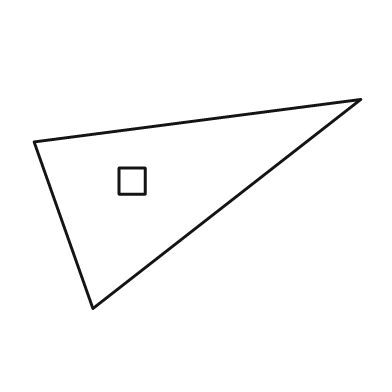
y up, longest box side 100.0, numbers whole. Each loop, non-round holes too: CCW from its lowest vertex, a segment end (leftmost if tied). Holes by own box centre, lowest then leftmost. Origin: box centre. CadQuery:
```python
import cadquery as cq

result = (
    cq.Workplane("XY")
    .moveTo(-32.0, -32.0)
    .lineTo(50.0, 32.0)
    .lineTo(-50.0, 19.0)
    .close()
    .moveTo(-24.0, 3.0)
    .lineTo(-16.0, 3.0)
    .lineTo(-16.0, 11.0)
    .lineTo(-24.0, 11.0)
    .close()
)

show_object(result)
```